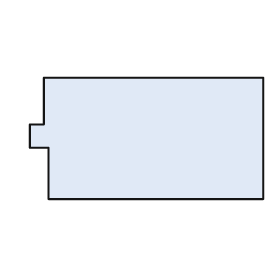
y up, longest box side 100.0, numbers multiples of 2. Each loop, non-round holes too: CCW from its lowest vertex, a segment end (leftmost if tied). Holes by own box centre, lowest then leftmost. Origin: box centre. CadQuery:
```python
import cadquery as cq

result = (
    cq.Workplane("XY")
    .moveTo(-42.0, -26.0)
    .lineTo(50.0, -26.0)
    .lineTo(50.0, 26.0)
    .lineTo(-44.0, 26.0)
    .lineTo(-44.0, 6.0)
    .lineTo(-50.0, 6.0)
    .lineTo(-50.0, -4.0)
    .lineTo(-42.0, -4.0)
    .close()
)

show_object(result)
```